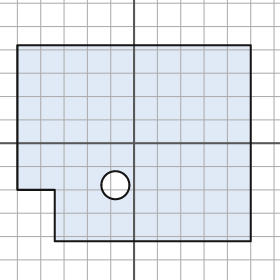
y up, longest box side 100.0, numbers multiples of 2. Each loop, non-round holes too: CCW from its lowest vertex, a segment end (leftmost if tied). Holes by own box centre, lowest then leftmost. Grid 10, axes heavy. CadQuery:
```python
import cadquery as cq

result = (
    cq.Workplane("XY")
    .moveTo(-34.0, -42.0)
    .lineTo(50.0, -42.0)
    .lineTo(50.0, 42.0)
    .lineTo(-50.0, 42.0)
    .lineTo(-50.0, -20.0)
    .lineTo(-34.0, -20.0)
    .close()
    .moveTo(-8.0, -18.0)
    .circle(6.0)
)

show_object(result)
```